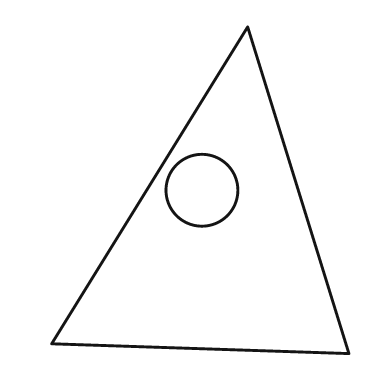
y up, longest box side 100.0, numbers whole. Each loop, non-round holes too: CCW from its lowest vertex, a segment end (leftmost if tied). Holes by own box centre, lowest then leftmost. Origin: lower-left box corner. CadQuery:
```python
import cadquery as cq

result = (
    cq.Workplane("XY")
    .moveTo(91.0, 0.0)
    .lineTo(60.0, 100.0)
    .lineTo(0.0, 3.0)
    .close()
    .moveTo(46.0, 50.0)
    .circle(11.0)
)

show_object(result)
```